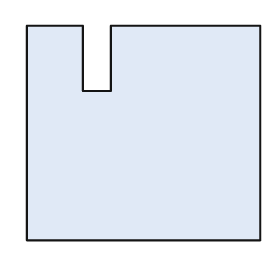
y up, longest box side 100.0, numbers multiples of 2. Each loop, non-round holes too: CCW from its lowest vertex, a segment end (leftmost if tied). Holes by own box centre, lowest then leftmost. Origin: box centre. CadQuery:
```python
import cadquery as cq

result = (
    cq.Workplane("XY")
    .moveTo(-50.0, -46.0)
    .lineTo(50.0, -46.0)
    .lineTo(50.0, 46.0)
    .lineTo(-14.0, 46.0)
    .lineTo(-14.0, 18.0)
    .lineTo(-26.0, 18.0)
    .lineTo(-26.0, 46.0)
    .lineTo(-50.0, 46.0)
    .close()
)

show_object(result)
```